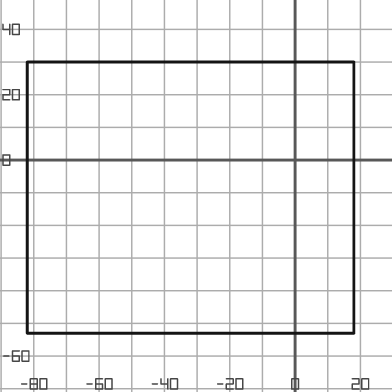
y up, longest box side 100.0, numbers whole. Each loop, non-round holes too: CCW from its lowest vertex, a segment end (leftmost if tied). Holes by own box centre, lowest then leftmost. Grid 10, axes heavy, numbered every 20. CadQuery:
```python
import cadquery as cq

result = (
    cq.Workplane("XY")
    .moveTo(-82.0, -53.0)
    .lineTo(18.0, -53.0)
    .lineTo(18.0, 30.0)
    .lineTo(-82.0, 30.0)
    .close()
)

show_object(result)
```